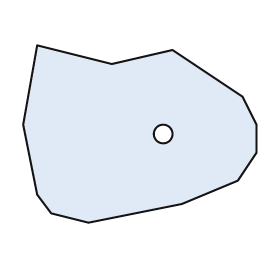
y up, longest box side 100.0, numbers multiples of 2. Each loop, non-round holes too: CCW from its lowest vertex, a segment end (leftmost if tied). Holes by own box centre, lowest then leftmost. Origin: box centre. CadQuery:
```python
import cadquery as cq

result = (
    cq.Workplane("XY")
    .moveTo(-22.0, -38.0)
    .lineTo(18.0, -30.0)
    .lineTo(42.0, -20.0)
    .lineTo(50.0, -8.0)
    .lineTo(50.0, 4.0)
    .lineTo(44.0, 16.0)
    .lineTo(14.0, 36.0)
    .lineTo(-12.0, 30.0)
    .lineTo(-44.0, 38.0)
    .lineTo(-50.0, 4.0)
    .lineTo(-44.0, -26.0)
    .lineTo(-38.0, -34.0)
    .close()
    .moveTo(10.0, 0.0)
    .circle(4.0)
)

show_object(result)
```